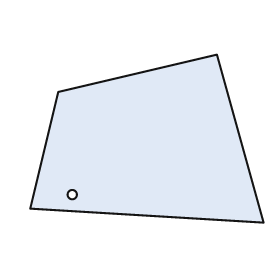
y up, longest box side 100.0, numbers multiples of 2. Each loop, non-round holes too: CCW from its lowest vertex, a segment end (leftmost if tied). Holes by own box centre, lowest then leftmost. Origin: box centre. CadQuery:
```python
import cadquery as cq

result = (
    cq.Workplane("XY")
    .moveTo(50.0, -36.0)
    .lineTo(30.0, 36.0)
    .lineTo(-38.0, 20.0)
    .lineTo(-50.0, -30.0)
    .close()
    .moveTo(-32.0, -24.0)
    .circle(2.0)
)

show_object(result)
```